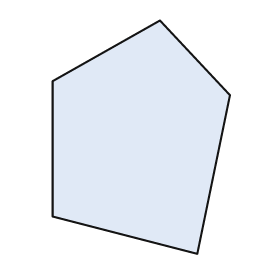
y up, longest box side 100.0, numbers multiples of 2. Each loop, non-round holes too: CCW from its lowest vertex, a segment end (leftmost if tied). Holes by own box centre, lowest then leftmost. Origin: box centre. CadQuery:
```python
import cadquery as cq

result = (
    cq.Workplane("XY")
    .moveTo(24.0, -50.0)
    .lineTo(38.0, 18.0)
    .lineTo(8.0, 50.0)
    .lineTo(-38.0, 24.0)
    .lineTo(-38.0, -34.0)
    .close()
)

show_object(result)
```